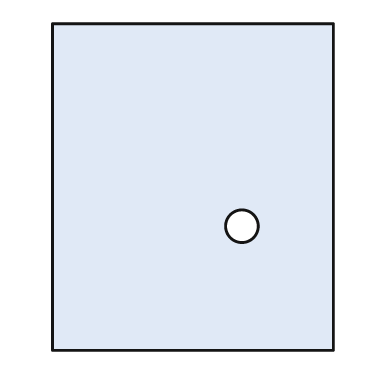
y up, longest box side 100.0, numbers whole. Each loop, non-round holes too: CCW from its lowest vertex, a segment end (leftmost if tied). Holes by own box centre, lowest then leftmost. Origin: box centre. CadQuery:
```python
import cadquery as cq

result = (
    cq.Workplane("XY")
    .moveTo(-43.0, -50.0)
    .lineTo(43.0, -50.0)
    .lineTo(43.0, 50.0)
    .lineTo(-43.0, 50.0)
    .close()
    .moveTo(15.0, -12.0)
    .circle(5.0)
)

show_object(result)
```